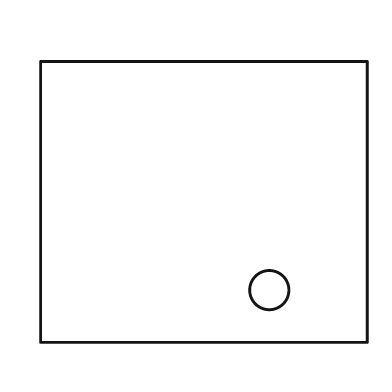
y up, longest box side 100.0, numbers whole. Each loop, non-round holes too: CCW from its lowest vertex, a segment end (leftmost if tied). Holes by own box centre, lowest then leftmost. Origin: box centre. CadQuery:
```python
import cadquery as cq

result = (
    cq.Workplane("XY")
    .moveTo(-50.0, -43.0)
    .lineTo(50.0, -43.0)
    .lineTo(50.0, 43.0)
    .lineTo(-50.0, 43.0)
    .close()
    .moveTo(20.0, -27.0)
    .circle(6.0)
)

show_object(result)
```